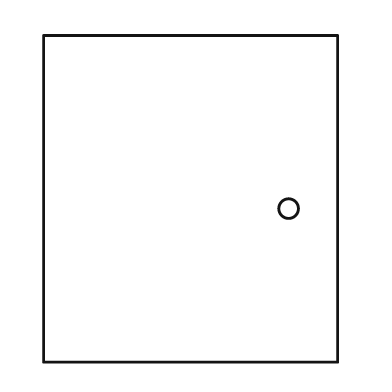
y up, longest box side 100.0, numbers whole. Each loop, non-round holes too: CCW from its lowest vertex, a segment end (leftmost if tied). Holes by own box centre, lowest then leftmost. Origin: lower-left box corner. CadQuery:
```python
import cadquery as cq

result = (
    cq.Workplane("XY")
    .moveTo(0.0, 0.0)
    .lineTo(90.0, 0.0)
    .lineTo(90.0, 100.0)
    .lineTo(0.0, 100.0)
    .close()
    .moveTo(75.0, 47.0)
    .circle(3.0)
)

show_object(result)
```